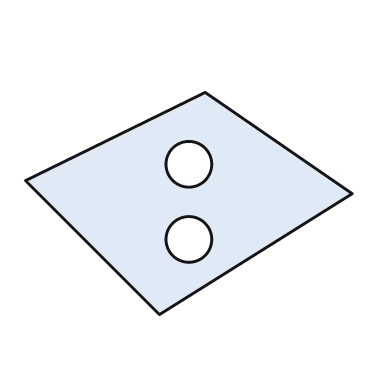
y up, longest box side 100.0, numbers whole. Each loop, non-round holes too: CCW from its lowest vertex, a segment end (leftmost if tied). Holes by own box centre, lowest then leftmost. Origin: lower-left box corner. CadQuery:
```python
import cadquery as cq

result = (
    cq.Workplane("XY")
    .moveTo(41.0, 0.0)
    .lineTo(100.0, 37.0)
    .lineTo(55.0, 68.0)
    .lineTo(0.0, 41.0)
    .close()
    .moveTo(50.0, 23.0)
    .circle(7.0)
    .moveTo(50.0, 46.0)
    .circle(7.0)
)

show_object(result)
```